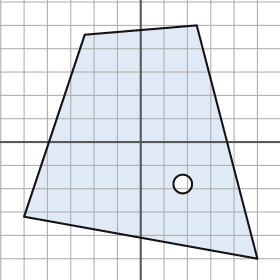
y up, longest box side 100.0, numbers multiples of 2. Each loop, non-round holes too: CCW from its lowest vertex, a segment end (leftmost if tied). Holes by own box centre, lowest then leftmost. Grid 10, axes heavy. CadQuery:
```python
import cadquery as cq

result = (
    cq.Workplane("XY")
    .moveTo(50.0, -50.0)
    .lineTo(24.0, 50.0)
    .lineTo(-24.0, 46.0)
    .lineTo(-50.0, -32.0)
    .close()
    .moveTo(18.0, -18.0)
    .circle(4.0)
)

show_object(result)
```